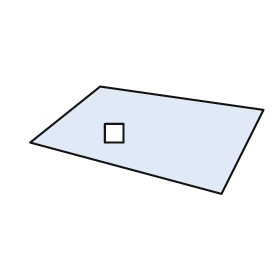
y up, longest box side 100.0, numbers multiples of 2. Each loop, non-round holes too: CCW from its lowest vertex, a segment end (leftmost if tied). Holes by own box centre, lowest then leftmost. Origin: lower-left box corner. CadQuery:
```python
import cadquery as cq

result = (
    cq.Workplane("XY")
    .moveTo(82.0, 0.0)
    .lineTo(100.0, 36.0)
    .lineTo(30.0, 46.0)
    .lineTo(0.0, 22.0)
    .close()
    .moveTo(32.0, 22.0)
    .lineTo(40.0, 22.0)
    .lineTo(40.0, 30.0)
    .lineTo(32.0, 30.0)
    .close()
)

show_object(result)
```